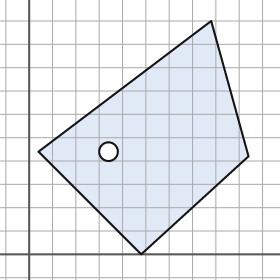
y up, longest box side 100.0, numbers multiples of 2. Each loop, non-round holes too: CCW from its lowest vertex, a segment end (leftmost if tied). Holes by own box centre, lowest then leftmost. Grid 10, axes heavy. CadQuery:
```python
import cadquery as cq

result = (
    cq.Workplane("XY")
    .moveTo(48.0, 0.0)
    .lineTo(94.0, 42.0)
    .lineTo(78.0, 100.0)
    .lineTo(4.0, 44.0)
    .close()
    .moveTo(34.0, 44.0)
    .circle(4.0)
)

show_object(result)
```